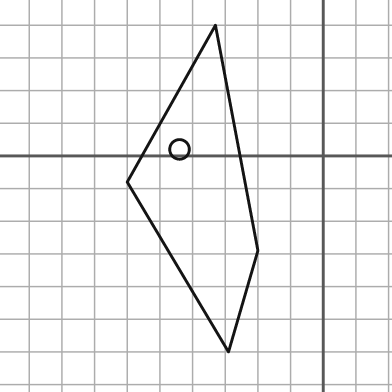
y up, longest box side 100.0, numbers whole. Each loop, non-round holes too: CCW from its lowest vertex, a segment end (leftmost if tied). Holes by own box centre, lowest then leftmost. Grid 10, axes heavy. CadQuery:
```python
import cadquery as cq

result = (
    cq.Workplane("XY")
    .moveTo(-29.0, -60.0)
    .lineTo(-20.0, -29.0)
    .lineTo(-33.0, 40.0)
    .lineTo(-60.0, -8.0)
    .close()
    .moveTo(-44.0, 2.0)
    .circle(3.0)
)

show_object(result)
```